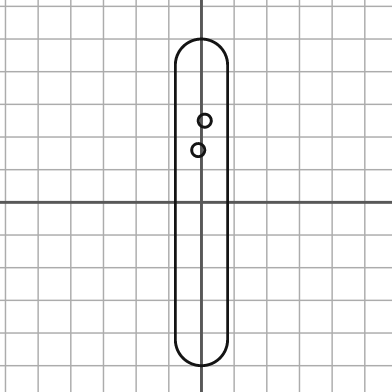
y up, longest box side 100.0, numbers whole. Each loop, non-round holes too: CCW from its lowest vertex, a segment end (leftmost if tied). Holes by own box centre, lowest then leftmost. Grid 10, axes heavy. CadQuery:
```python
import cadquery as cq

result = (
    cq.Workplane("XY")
    .moveTo(-8.0, -42.0)
    .threePointArc((0.0, -50.0), (8.0, -42.0))
    .lineTo(8.0, 42.0)
    .threePointArc((0.0, 50.0), (-8.0, 42.0))
    .close()
    .moveTo(-1.0, 16.0)
    .circle(2.0)
    .moveTo(1.0, 25.0)
    .circle(2.0)
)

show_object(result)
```